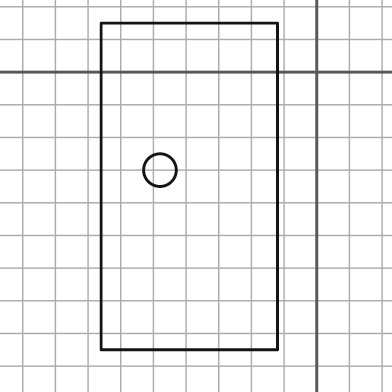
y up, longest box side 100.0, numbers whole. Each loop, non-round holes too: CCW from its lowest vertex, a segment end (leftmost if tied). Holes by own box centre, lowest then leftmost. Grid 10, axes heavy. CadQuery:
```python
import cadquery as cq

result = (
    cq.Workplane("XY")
    .moveTo(-66.0, -85.0)
    .lineTo(-12.0, -85.0)
    .lineTo(-12.0, 15.0)
    .lineTo(-66.0, 15.0)
    .close()
    .moveTo(-48.0, -30.0)
    .circle(5.0)
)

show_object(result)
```